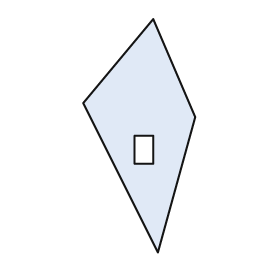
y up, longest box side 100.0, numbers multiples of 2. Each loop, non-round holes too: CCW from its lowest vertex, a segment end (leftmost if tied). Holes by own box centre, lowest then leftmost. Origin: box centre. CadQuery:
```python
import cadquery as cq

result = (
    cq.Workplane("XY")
    .moveTo(8.0, -50.0)
    .lineTo(24.0, 8.0)
    .lineTo(6.0, 50.0)
    .lineTo(-24.0, 14.0)
    .close()
    .moveTo(-2.0, -12.0)
    .lineTo(6.0, -12.0)
    .lineTo(6.0, 0.0)
    .lineTo(-2.0, 0.0)
    .close()
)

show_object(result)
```